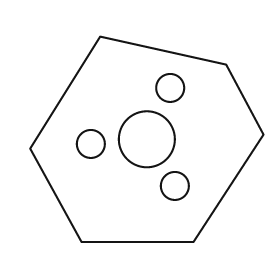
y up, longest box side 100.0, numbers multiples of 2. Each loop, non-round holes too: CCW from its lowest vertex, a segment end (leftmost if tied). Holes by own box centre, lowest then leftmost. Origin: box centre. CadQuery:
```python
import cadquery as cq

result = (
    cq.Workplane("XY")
    .moveTo(-28.0, -44.0)
    .lineTo(20.0, -44.0)
    .lineTo(50.0, 2.0)
    .lineTo(34.0, 32.0)
    .lineTo(-20.0, 44.0)
    .lineTo(-50.0, -4.0)
    .close()
    .moveTo(12.0, -20.0)
    .circle(6.0)
    .moveTo(-24.0, -2.0)
    .circle(6.0)
    .moveTo(0.0, 0.0)
    .circle(12.0)
    .moveTo(10.0, 22.0)
    .circle(6.0)
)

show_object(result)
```